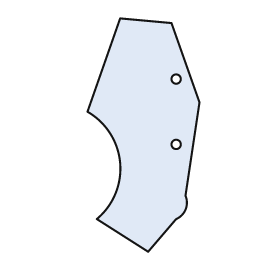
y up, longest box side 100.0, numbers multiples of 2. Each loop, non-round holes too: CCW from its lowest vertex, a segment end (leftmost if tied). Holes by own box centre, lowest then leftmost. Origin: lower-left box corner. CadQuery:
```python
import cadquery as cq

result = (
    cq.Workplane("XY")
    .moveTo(26.0, 0.0)
    .lineTo(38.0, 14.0)
    .threePointArc((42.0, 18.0), (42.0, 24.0))
    .lineTo(48.0, 64.0)
    .lineTo(36.0, 98.0)
    .lineTo(14.0, 100.0)
    .lineTo(0.0, 60.0)
    .threePointArc((14.0, 38.0), (4.0, 14.0))
    .close()
    .moveTo(38.0, 46.0)
    .circle(2.0)
    .moveTo(38.0, 74.0)
    .circle(2.0)
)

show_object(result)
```